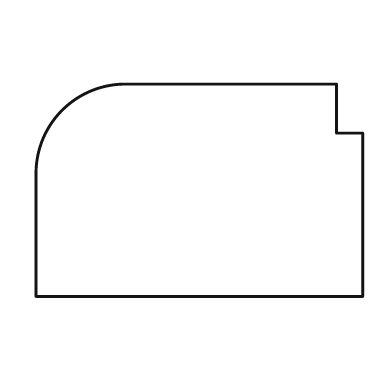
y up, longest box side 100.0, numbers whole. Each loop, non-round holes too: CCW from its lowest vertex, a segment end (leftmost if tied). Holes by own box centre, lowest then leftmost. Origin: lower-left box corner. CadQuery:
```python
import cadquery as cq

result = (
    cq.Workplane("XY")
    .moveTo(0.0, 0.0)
    .lineTo(100.0, 0.0)
    .lineTo(100.0, 50.0)
    .lineTo(92.0, 50.0)
    .lineTo(92.0, 65.0)
    .lineTo(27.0, 65.0)
    .threePointArc((8.0, 57.0), (0.0, 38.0))
    .close()
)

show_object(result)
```